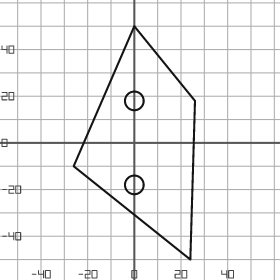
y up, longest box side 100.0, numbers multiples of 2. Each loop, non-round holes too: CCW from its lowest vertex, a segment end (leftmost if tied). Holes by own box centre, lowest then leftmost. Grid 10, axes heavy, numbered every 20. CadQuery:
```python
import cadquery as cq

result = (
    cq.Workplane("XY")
    .moveTo(24.0, -50.0)
    .lineTo(26.0, 18.0)
    .lineTo(0.0, 50.0)
    .lineTo(-26.0, -10.0)
    .close()
    .moveTo(0.0, -18.0)
    .circle(4.0)
    .moveTo(0.0, 18.0)
    .circle(4.0)
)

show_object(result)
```